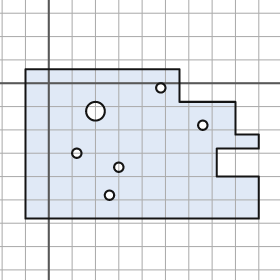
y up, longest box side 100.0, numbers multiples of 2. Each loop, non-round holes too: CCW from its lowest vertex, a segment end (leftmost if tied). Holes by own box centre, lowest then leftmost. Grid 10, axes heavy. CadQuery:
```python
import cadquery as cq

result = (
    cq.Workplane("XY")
    .moveTo(-10.0, -58.0)
    .lineTo(90.0, -58.0)
    .lineTo(90.0, -40.0)
    .lineTo(72.0, -40.0)
    .lineTo(72.0, -28.0)
    .lineTo(90.0, -28.0)
    .lineTo(90.0, -22.0)
    .lineTo(80.0, -22.0)
    .lineTo(80.0, -8.0)
    .lineTo(56.0, -8.0)
    .lineTo(56.0, 6.0)
    .lineTo(-10.0, 6.0)
    .close()
    .moveTo(26.0, -48.0)
    .circle(2.0)
    .moveTo(30.0, -36.0)
    .circle(2.0)
    .moveTo(12.0, -30.0)
    .circle(2.0)
    .moveTo(66.0, -18.0)
    .circle(2.0)
    .moveTo(20.0, -12.0)
    .circle(4.0)
    .moveTo(48.0, -2.0)
    .circle(2.0)
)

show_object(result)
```